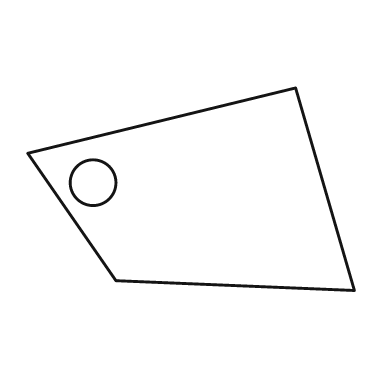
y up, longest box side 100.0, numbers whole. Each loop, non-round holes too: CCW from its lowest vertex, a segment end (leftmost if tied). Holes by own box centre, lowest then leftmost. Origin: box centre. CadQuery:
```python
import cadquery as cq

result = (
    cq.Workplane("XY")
    .moveTo(50.0, -31.0)
    .lineTo(32.0, 31.0)
    .lineTo(-50.0, 11.0)
    .lineTo(-23.0, -28.0)
    .close()
    .moveTo(-30.0, 2.0)
    .circle(7.0)
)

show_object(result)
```